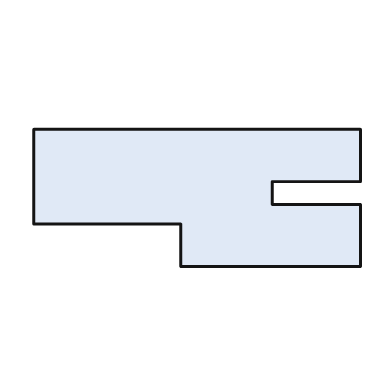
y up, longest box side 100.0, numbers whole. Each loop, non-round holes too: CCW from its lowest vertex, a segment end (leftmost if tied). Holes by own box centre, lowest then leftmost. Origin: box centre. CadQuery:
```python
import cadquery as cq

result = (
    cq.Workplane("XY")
    .moveTo(-5.0, -21.0)
    .lineTo(50.0, -21.0)
    .lineTo(50.0, -2.0)
    .lineTo(23.0, -2.0)
    .lineTo(23.0, 5.0)
    .lineTo(50.0, 5.0)
    .lineTo(50.0, 21.0)
    .lineTo(-50.0, 21.0)
    .lineTo(-50.0, -8.0)
    .lineTo(-5.0, -8.0)
    .close()
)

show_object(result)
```